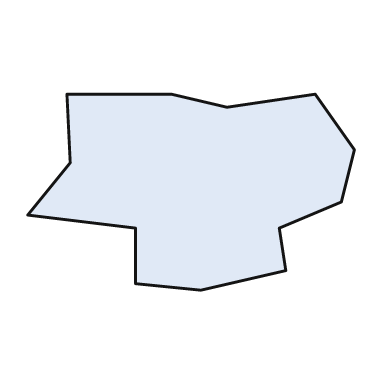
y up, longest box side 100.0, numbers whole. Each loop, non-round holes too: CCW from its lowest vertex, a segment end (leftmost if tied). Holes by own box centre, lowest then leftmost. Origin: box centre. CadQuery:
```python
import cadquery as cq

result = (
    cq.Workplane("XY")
    .moveTo(3.0, -30.0)
    .lineTo(29.0, -24.0)
    .lineTo(27.0, -11.0)
    .lineTo(46.0, -3.0)
    .lineTo(50.0, 13.0)
    .lineTo(38.0, 30.0)
    .lineTo(11.0, 26.0)
    .lineTo(-6.0, 30.0)
    .lineTo(-38.0, 30.0)
    .lineTo(-37.0, 9.0)
    .lineTo(-50.0, -7.0)
    .lineTo(-17.0, -11.0)
    .lineTo(-17.0, -28.0)
    .close()
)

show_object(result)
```